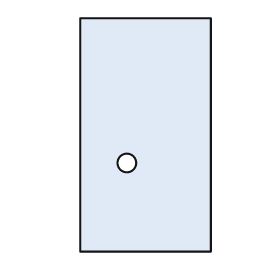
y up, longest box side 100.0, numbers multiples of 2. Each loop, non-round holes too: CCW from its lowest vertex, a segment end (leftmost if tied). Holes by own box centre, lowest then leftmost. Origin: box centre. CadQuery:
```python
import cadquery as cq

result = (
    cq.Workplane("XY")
    .moveTo(-28.0, -50.0)
    .lineTo(28.0, -50.0)
    .lineTo(28.0, 50.0)
    .lineTo(-28.0, 50.0)
    .close()
    .moveTo(-8.0, -12.0)
    .circle(4.0)
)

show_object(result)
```